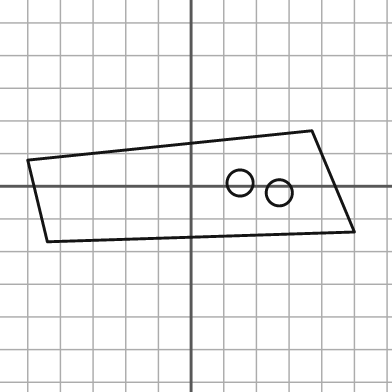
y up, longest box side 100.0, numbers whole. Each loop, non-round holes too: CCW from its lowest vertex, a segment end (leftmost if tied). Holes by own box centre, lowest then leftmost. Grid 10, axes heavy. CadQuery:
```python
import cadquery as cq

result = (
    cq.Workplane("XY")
    .moveTo(-44.0, -17.0)
    .lineTo(50.0, -14.0)
    .lineTo(37.0, 17.0)
    .lineTo(-50.0, 8.0)
    .close()
    .moveTo(27.0, -2.0)
    .circle(4.0)
    .moveTo(15.0, 1.0)
    .circle(4.0)
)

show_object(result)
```